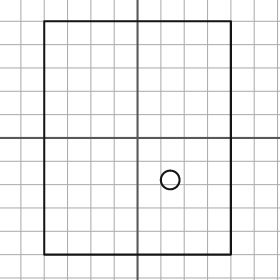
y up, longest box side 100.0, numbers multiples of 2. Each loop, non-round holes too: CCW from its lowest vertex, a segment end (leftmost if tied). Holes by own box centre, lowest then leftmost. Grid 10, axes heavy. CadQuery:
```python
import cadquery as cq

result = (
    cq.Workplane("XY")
    .moveTo(-40.0, -50.0)
    .lineTo(40.0, -50.0)
    .lineTo(40.0, 50.0)
    .lineTo(-40.0, 50.0)
    .close()
    .moveTo(14.0, -18.0)
    .circle(4.0)
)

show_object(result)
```